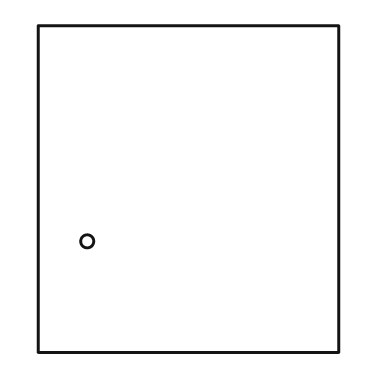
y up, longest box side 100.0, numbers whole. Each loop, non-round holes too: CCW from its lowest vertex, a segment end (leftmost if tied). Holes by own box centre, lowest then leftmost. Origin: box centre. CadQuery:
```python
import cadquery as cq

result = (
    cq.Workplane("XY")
    .moveTo(-46.0, -50.0)
    .lineTo(46.0, -50.0)
    .lineTo(46.0, 50.0)
    .lineTo(-46.0, 50.0)
    .close()
    .moveTo(-31.0, -16.0)
    .circle(2.0)
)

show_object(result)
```